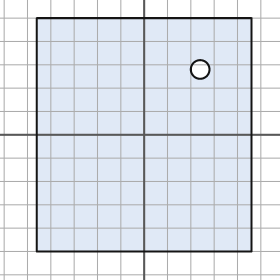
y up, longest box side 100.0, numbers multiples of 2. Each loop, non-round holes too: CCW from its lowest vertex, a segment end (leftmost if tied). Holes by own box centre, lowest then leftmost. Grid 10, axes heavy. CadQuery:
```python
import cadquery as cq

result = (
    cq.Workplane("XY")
    .moveTo(-46.0, -50.0)
    .lineTo(46.0, -50.0)
    .lineTo(46.0, 50.0)
    .lineTo(-46.0, 50.0)
    .close()
    .moveTo(24.0, 28.0)
    .circle(4.0)
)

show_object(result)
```